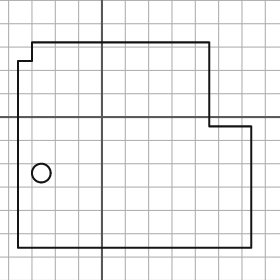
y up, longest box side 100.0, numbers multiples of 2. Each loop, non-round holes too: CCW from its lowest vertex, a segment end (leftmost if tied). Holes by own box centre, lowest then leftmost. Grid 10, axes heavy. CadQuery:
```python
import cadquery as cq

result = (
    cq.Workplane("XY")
    .moveTo(-36.0, -56.0)
    .lineTo(64.0, -56.0)
    .lineTo(64.0, -4.0)
    .lineTo(46.0, -4.0)
    .lineTo(46.0, 32.0)
    .lineTo(-30.0, 32.0)
    .lineTo(-30.0, 24.0)
    .lineTo(-36.0, 24.0)
    .close()
    .moveTo(-26.0, -24.0)
    .circle(4.0)
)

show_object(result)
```